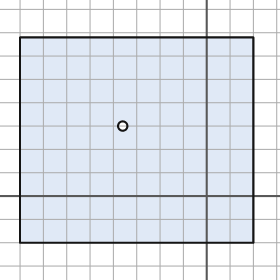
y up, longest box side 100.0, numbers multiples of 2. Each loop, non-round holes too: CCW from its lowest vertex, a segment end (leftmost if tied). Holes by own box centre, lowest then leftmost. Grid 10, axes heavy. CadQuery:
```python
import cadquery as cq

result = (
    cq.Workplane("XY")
    .moveTo(-80.0, -20.0)
    .lineTo(20.0, -20.0)
    .lineTo(20.0, 68.0)
    .lineTo(-80.0, 68.0)
    .close()
    .moveTo(-36.0, 30.0)
    .circle(2.0)
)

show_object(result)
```